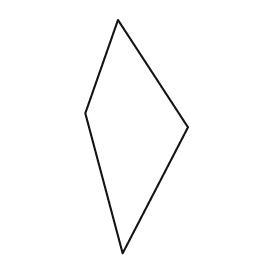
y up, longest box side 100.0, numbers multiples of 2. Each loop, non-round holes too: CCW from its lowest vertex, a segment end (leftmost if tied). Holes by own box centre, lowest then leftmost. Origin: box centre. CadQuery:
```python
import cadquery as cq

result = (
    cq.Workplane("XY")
    .moveTo(-6.0, -50.0)
    .lineTo(22.0, 4.0)
    .lineTo(-8.0, 50.0)
    .lineTo(-22.0, 10.0)
    .close()
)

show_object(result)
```